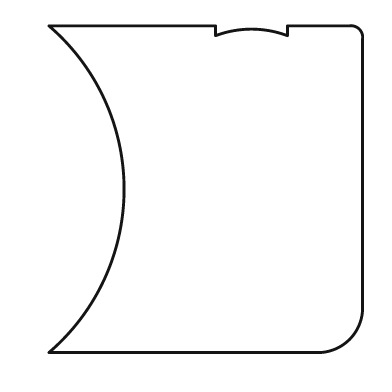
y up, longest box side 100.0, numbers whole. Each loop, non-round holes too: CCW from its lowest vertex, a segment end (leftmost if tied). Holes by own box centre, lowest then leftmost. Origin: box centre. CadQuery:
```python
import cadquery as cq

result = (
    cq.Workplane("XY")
    .moveTo(-48.0, -50.0)
    .lineTo(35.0, -50.0)
    .threePointArc((44.0, -46.0), (48.0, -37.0))
    .lineTo(48.0, 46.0)
    .threePointArc((47.0, 49.0), (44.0, 50.0))
    .lineTo(25.0, 50.0)
    .lineTo(25.0, 47.0)
    .threePointArc((14.0, 49.0), (3.0, 47.0))
    .lineTo(3.0, 50.0)
    .lineTo(-48.0, 50.0)
    .threePointArc((-25.0, 0.0), (-48.0, -50.0))
    .close()
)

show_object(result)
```